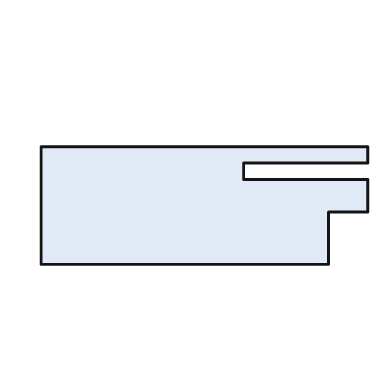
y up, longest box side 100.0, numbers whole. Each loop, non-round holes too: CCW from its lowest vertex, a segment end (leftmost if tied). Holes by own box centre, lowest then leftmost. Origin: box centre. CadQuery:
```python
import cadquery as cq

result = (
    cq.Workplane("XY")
    .moveTo(-50.0, -18.0)
    .lineTo(38.0, -18.0)
    .lineTo(38.0, -2.0)
    .lineTo(50.0, -2.0)
    .lineTo(50.0, 8.0)
    .lineTo(12.0, 8.0)
    .lineTo(12.0, 13.0)
    .lineTo(50.0, 13.0)
    .lineTo(50.0, 18.0)
    .lineTo(-50.0, 18.0)
    .close()
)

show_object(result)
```